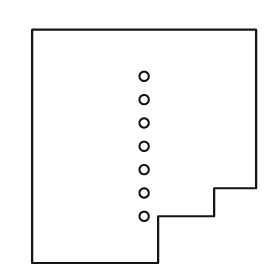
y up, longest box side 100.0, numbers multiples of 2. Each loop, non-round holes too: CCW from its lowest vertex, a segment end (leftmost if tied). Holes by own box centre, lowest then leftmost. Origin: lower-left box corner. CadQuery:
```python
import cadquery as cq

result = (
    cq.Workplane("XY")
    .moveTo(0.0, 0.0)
    .lineTo(54.0, 0.0)
    .lineTo(54.0, 20.0)
    .lineTo(78.0, 20.0)
    .lineTo(78.0, 32.0)
    .lineTo(96.0, 32.0)
    .lineTo(96.0, 100.0)
    .lineTo(0.0, 100.0)
    .close()
    .moveTo(48.0, 20.0)
    .circle(2.0)
    .moveTo(48.0, 30.0)
    .circle(2.0)
    .moveTo(48.0, 40.0)
    .circle(2.0)
    .moveTo(48.0, 50.0)
    .circle(2.0)
    .moveTo(48.0, 60.0)
    .circle(2.0)
    .moveTo(48.0, 70.0)
    .circle(2.0)
    .moveTo(48.0, 80.0)
    .circle(2.0)
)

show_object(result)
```